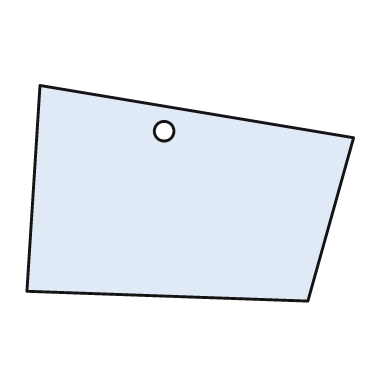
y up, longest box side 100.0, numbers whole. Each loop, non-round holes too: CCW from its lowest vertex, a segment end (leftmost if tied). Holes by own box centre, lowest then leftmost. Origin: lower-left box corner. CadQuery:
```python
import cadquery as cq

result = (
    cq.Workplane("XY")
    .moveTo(86.0, 0.0)
    .lineTo(100.0, 50.0)
    .lineTo(4.0, 66.0)
    .lineTo(0.0, 3.0)
    .close()
    .moveTo(42.0, 52.0)
    .circle(3.0)
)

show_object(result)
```